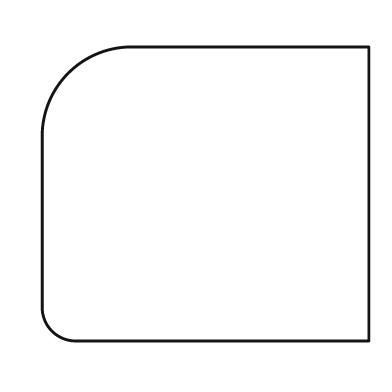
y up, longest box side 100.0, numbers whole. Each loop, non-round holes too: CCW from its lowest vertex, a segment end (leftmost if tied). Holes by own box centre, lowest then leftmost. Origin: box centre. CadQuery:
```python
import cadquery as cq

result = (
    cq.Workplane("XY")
    .moveTo(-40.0, -45.0)
    .lineTo(50.0, -45.0)
    .lineTo(50.0, 45.0)
    .lineTo(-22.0, 45.0)
    .threePointArc((-42.0, 37.0), (-50.0, 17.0))
    .lineTo(-50.0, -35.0)
    .threePointArc((-47.0, -42.0), (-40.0, -45.0))
    .close()
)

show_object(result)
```